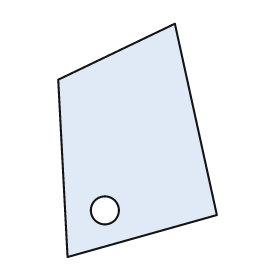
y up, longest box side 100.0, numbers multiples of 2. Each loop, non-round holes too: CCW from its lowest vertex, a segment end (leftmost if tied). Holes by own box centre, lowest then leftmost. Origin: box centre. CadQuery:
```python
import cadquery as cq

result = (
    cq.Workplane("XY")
    .moveTo(-30.0, -50.0)
    .lineTo(34.0, -32.0)
    .lineTo(16.0, 50.0)
    .lineTo(-34.0, 26.0)
    .close()
    .moveTo(-14.0, -30.0)
    .circle(6.0)
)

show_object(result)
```